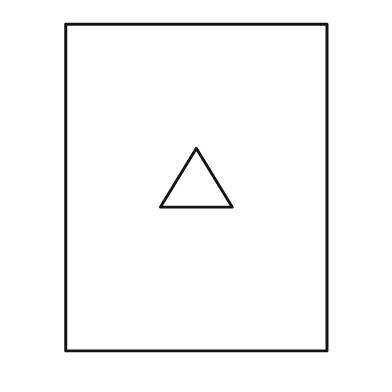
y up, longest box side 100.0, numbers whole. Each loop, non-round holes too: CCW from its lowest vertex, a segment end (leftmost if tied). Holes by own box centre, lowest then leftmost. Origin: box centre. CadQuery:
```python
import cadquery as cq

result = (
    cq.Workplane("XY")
    .moveTo(-40.0, -50.0)
    .lineTo(40.0, -50.0)
    .lineTo(40.0, 50.0)
    .lineTo(-40.0, 50.0)
    .close()
    .moveTo(-11.0, -6.0)
    .lineTo(11.0, -6.0)
    .lineTo(0.0, 12.0)
    .close()
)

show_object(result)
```